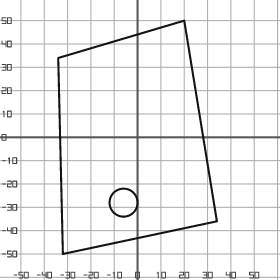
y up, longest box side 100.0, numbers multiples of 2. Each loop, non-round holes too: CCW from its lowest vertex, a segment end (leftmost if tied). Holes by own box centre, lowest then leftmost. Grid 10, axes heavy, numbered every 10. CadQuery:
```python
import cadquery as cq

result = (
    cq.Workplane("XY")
    .moveTo(-32.0, -50.0)
    .lineTo(34.0, -36.0)
    .lineTo(20.0, 50.0)
    .lineTo(-34.0, 34.0)
    .close()
    .moveTo(-6.0, -28.0)
    .circle(6.0)
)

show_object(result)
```